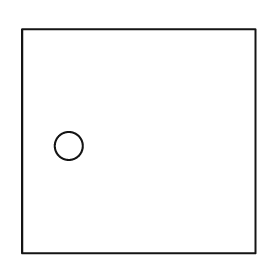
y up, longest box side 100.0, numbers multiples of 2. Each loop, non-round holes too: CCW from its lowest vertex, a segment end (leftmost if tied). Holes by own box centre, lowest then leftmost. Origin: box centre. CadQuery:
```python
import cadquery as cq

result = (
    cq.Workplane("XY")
    .moveTo(-50.0, -48.0)
    .lineTo(50.0, -48.0)
    .lineTo(50.0, 48.0)
    .lineTo(-50.0, 48.0)
    .close()
    .moveTo(-30.0, -2.0)
    .circle(6.0)
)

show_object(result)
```